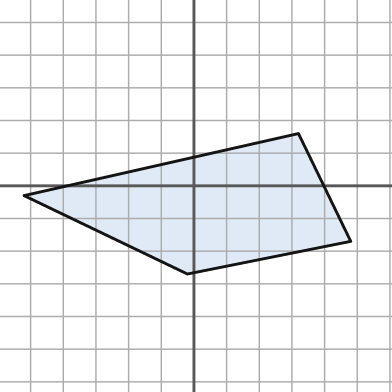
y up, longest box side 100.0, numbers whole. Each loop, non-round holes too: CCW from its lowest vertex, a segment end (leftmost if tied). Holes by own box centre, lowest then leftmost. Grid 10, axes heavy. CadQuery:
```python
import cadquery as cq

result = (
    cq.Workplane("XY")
    .moveTo(-2.0, -27.0)
    .lineTo(48.0, -17.0)
    .lineTo(32.0, 16.0)
    .lineTo(-52.0, -3.0)
    .close()
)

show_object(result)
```